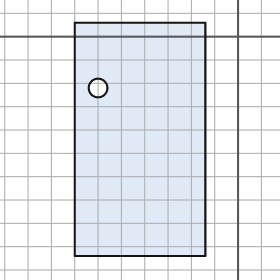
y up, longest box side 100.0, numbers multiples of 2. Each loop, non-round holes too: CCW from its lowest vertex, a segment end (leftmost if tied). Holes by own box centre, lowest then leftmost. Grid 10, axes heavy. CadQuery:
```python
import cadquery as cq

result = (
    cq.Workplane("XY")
    .moveTo(-70.0, -94.0)
    .lineTo(-14.0, -94.0)
    .lineTo(-14.0, 6.0)
    .lineTo(-70.0, 6.0)
    .close()
    .moveTo(-60.0, -22.0)
    .circle(4.0)
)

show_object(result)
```